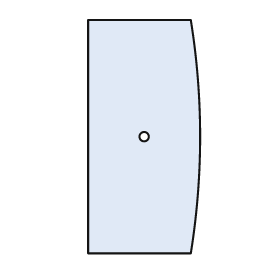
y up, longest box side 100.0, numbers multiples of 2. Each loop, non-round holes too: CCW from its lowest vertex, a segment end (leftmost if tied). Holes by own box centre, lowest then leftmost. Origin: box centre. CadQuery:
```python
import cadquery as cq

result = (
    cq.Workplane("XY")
    .moveTo(-24.0, -50.0)
    .lineTo(20.0, -50.0)
    .threePointArc((24.0, 0.0), (20.0, 50.0))
    .lineTo(-24.0, 50.0)
    .close()
    .moveTo(0.0, 0.0)
    .circle(2.0)
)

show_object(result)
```